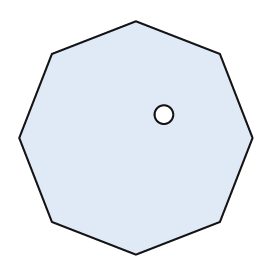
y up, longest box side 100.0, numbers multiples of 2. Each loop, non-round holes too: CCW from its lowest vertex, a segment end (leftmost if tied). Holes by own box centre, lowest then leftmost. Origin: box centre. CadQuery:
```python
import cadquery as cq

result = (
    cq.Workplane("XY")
    .moveTo(0.0, -50.0)
    .lineTo(36.0, -36.0)
    .lineTo(50.0, 0.0)
    .lineTo(36.0, 36.0)
    .lineTo(0.0, 50.0)
    .lineTo(-36.0, 36.0)
    .lineTo(-50.0, 0.0)
    .lineTo(-36.0, -36.0)
    .close()
    .moveTo(12.0, 10.0)
    .circle(4.0)
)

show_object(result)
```